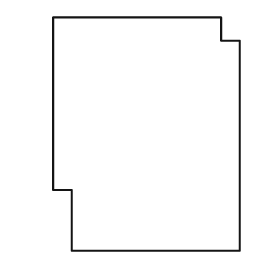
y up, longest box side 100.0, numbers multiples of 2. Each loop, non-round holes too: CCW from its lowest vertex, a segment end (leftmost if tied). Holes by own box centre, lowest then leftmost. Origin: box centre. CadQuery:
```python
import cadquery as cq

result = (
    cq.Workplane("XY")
    .moveTo(-32.0, -50.0)
    .lineTo(40.0, -50.0)
    .lineTo(40.0, 40.0)
    .lineTo(32.0, 40.0)
    .lineTo(32.0, 50.0)
    .lineTo(-40.0, 50.0)
    .lineTo(-40.0, -24.0)
    .lineTo(-32.0, -24.0)
    .close()
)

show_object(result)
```